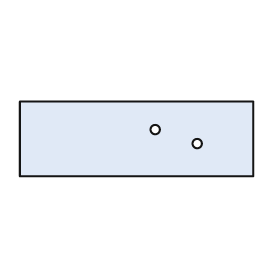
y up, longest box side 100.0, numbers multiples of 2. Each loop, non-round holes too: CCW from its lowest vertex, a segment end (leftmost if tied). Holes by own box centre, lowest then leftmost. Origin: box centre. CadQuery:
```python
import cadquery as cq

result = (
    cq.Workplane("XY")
    .moveTo(-50.0, -16.0)
    .lineTo(50.0, -16.0)
    .lineTo(50.0, 16.0)
    .lineTo(-50.0, 16.0)
    .close()
    .moveTo(26.0, -2.0)
    .circle(2.0)
    .moveTo(8.0, 4.0)
    .circle(2.0)
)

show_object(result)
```